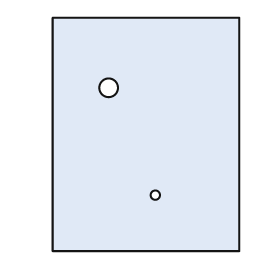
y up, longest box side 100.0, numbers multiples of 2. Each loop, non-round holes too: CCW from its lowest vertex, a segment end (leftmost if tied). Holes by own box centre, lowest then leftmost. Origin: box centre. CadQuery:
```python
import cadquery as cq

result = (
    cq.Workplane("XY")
    .moveTo(-40.0, -50.0)
    .lineTo(40.0, -50.0)
    .lineTo(40.0, 50.0)
    .lineTo(-40.0, 50.0)
    .close()
    .moveTo(4.0, -26.0)
    .circle(2.0)
    .moveTo(-16.0, 20.0)
    .circle(4.0)
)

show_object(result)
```